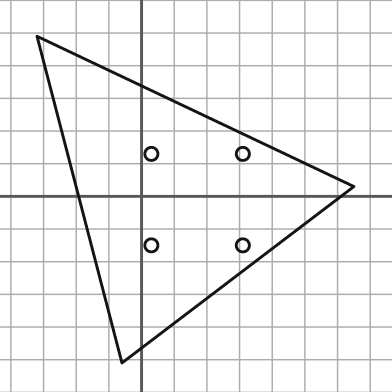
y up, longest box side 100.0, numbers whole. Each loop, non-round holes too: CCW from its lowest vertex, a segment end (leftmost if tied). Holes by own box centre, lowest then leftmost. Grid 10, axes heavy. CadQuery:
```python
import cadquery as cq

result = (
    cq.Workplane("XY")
    .moveTo(-6.0, -51.0)
    .lineTo(65.0, 3.0)
    .lineTo(-32.0, 49.0)
    .close()
    .moveTo(3.0, -15.0)
    .circle(2.0)
    .moveTo(31.0, -15.0)
    .circle(2.0)
    .moveTo(3.0, 13.0)
    .circle(2.0)
    .moveTo(31.0, 13.0)
    .circle(2.0)
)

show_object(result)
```